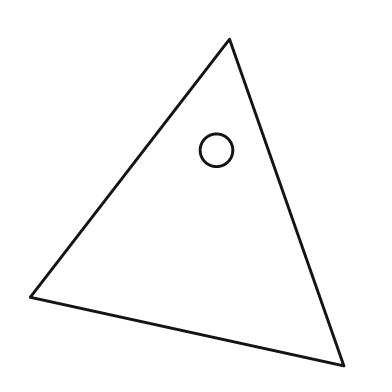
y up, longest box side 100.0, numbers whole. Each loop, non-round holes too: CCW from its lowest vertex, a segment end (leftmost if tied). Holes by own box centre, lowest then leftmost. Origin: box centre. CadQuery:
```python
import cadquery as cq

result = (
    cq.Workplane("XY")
    .moveTo(48.0, -50.0)
    .lineTo(13.0, 50.0)
    .lineTo(-48.0, -29.0)
    .close()
    .moveTo(9.0, 16.0)
    .circle(5.0)
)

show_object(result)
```